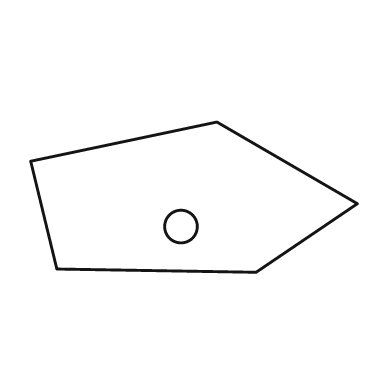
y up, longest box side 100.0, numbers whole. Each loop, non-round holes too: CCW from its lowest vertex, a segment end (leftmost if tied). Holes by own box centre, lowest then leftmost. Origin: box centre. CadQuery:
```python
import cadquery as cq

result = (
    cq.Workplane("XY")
    .moveTo(19.0, -23.0)
    .lineTo(50.0, -2.0)
    .lineTo(7.0, 23.0)
    .lineTo(-50.0, 11.0)
    .lineTo(-42.0, -22.0)
    .close()
    .moveTo(-4.0, -9.0)
    .circle(5.0)
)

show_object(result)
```